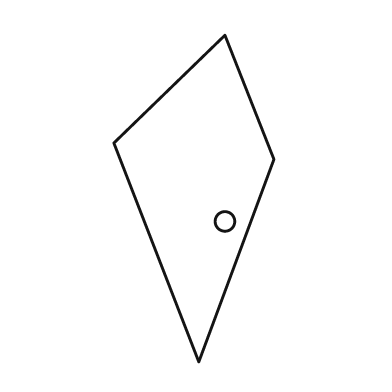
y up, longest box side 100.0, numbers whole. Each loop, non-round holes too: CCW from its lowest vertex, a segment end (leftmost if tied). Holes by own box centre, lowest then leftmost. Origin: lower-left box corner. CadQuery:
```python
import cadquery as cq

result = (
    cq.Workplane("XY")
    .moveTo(26.0, 0.0)
    .lineTo(49.0, 62.0)
    .lineTo(34.0, 100.0)
    .lineTo(0.0, 67.0)
    .close()
    .moveTo(34.0, 43.0)
    .circle(3.0)
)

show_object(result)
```